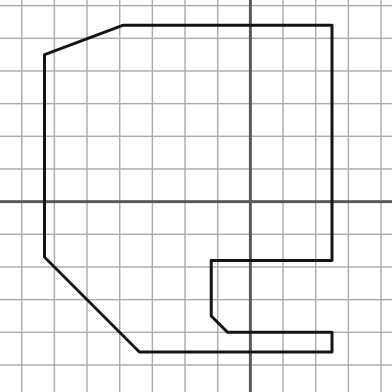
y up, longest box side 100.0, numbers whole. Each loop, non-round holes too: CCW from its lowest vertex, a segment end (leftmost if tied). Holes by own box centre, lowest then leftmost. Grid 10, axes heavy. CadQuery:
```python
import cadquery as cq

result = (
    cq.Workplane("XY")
    .moveTo(-34.0, -46.0)
    .lineTo(25.0, -46.0)
    .lineTo(25.0, -40.0)
    .lineTo(-7.0, -40.0)
    .lineTo(-12.0, -35.0)
    .lineTo(-12.0, -18.0)
    .lineTo(25.0, -18.0)
    .lineTo(25.0, 54.0)
    .lineTo(-39.0, 54.0)
    .lineTo(-63.0, 45.0)
    .lineTo(-63.0, -17.0)
    .close()
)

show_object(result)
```